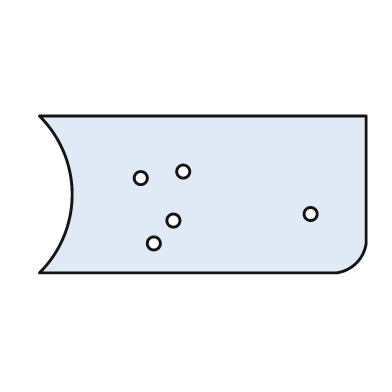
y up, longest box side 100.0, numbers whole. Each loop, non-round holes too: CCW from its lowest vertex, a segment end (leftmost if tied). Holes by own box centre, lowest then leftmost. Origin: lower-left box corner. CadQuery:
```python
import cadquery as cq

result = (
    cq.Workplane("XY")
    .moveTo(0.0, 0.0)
    .lineTo(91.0, 0.0)
    .threePointArc((97.0, 3.0), (100.0, 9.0))
    .lineTo(100.0, 48.0)
    .lineTo(0.0, 48.0)
    .threePointArc((10.0, 24.0), (0.0, 0.0))
    .close()
    .moveTo(35.0, 9.0)
    .circle(2.0)
    .moveTo(41.0, 16.0)
    .circle(2.0)
    .moveTo(83.0, 18.0)
    .circle(2.0)
    .moveTo(31.0, 29.0)
    .circle(2.0)
    .moveTo(44.0, 31.0)
    .circle(2.0)
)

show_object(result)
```